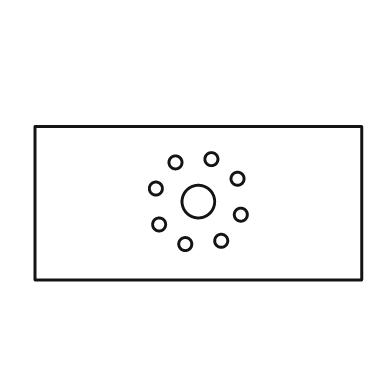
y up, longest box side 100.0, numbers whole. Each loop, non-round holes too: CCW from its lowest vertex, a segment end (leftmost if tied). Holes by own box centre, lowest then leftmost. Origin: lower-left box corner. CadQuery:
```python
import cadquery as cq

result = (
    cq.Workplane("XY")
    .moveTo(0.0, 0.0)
    .lineTo(100.0, 0.0)
    .lineTo(100.0, 47.0)
    .lineTo(0.0, 47.0)
    .close()
    .moveTo(46.0, 11.0)
    .circle(2.0)
    .moveTo(57.0, 12.0)
    .circle(2.0)
    .moveTo(38.0, 17.0)
    .circle(2.0)
    .moveTo(63.0, 20.0)
    .circle(2.0)
    .moveTo(50.0, 24.0)
    .circle(5.0)
    .moveTo(37.0, 28.0)
    .circle(2.0)
    .moveTo(62.0, 31.0)
    .circle(2.0)
    .moveTo(43.0, 36.0)
    .circle(2.0)
    .moveTo(54.0, 37.0)
    .circle(2.0)
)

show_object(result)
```